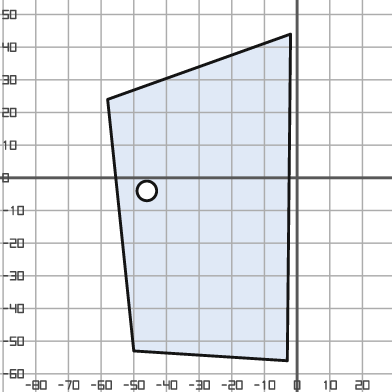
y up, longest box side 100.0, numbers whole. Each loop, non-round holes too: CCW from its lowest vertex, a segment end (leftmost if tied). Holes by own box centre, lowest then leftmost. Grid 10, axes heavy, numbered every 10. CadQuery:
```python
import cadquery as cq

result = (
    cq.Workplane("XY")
    .moveTo(-3.0, -56.0)
    .lineTo(-2.0, 44.0)
    .lineTo(-58.0, 24.0)
    .lineTo(-50.0, -53.0)
    .close()
    .moveTo(-46.0, -4.0)
    .circle(3.0)
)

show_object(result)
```